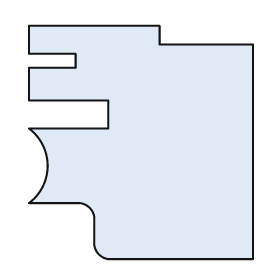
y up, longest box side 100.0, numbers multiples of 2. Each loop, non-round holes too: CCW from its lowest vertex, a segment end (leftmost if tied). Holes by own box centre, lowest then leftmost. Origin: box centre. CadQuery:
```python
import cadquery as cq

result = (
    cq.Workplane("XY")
    .moveTo(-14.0, -50.0)
    .lineTo(48.0, -50.0)
    .lineTo(48.0, 42.0)
    .lineTo(8.0, 42.0)
    .lineTo(8.0, 50.0)
    .lineTo(-48.0, 50.0)
    .lineTo(-48.0, 38.0)
    .lineTo(-28.0, 38.0)
    .lineTo(-28.0, 32.0)
    .lineTo(-48.0, 32.0)
    .lineTo(-48.0, 18.0)
    .lineTo(-14.0, 18.0)
    .lineTo(-14.0, 6.0)
    .lineTo(-48.0, 6.0)
    .threePointArc((-40.0, -10.0), (-48.0, -26.0))
    .lineTo(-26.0, -26.0)
    .threePointArc((-22.0, -28.0), (-20.0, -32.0))
    .lineTo(-20.0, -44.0)
    .threePointArc((-18.0, -48.0), (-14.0, -50.0))
    .close()
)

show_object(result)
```